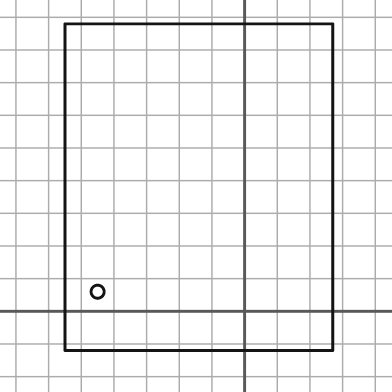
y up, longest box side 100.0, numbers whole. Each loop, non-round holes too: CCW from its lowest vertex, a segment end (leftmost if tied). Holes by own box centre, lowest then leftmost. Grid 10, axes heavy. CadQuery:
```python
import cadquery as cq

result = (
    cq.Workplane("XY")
    .moveTo(-55.0, -12.0)
    .lineTo(27.0, -12.0)
    .lineTo(27.0, 88.0)
    .lineTo(-55.0, 88.0)
    .close()
    .moveTo(-45.0, 6.0)
    .circle(2.0)
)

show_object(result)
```